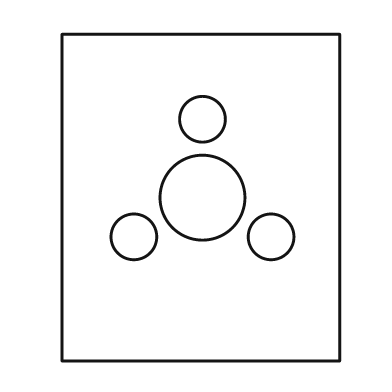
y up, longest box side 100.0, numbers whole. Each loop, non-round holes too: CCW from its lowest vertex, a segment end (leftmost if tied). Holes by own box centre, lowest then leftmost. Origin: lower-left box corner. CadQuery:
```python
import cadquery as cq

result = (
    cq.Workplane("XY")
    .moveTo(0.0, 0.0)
    .lineTo(85.0, 0.0)
    .lineTo(85.0, 100.0)
    .lineTo(0.0, 100.0)
    .close()
    .moveTo(22.0, 38.0)
    .circle(7.0)
    .moveTo(64.0, 38.0)
    .circle(7.0)
    .moveTo(43.0, 50.0)
    .circle(13.0)
    .moveTo(43.0, 74.0)
    .circle(7.0)
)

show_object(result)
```